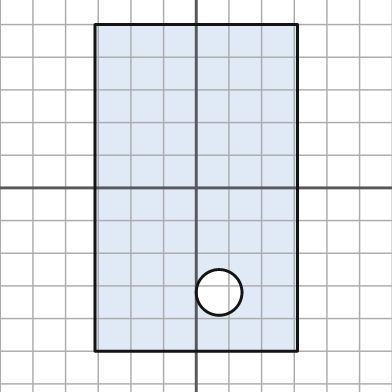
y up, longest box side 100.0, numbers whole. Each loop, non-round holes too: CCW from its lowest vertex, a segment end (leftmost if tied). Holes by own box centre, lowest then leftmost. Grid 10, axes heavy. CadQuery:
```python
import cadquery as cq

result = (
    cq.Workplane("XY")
    .moveTo(-31.0, -50.0)
    .lineTo(31.0, -50.0)
    .lineTo(31.0, 50.0)
    .lineTo(-31.0, 50.0)
    .close()
    .moveTo(7.0, -32.0)
    .circle(7.0)
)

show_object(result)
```